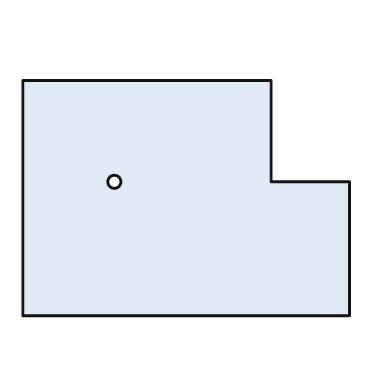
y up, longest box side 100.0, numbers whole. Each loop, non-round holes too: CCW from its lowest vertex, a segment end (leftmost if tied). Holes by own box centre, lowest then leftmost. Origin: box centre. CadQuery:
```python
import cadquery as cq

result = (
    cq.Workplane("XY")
    .moveTo(-50.0, -36.0)
    .lineTo(50.0, -36.0)
    .lineTo(50.0, 5.0)
    .lineTo(26.0, 5.0)
    .lineTo(26.0, 36.0)
    .lineTo(-50.0, 36.0)
    .close()
    .moveTo(-22.0, 5.0)
    .circle(2.0)
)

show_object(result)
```